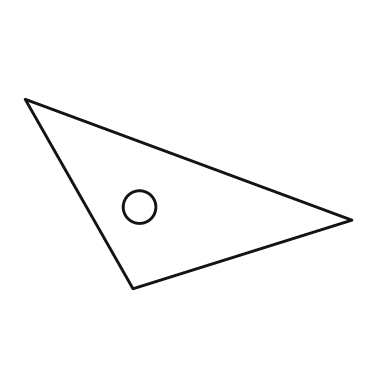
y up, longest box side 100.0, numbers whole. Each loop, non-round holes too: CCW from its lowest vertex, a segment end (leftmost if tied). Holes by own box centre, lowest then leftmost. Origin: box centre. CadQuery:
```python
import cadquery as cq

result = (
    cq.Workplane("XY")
    .moveTo(-17.0, -29.0)
    .lineTo(50.0, -8.0)
    .lineTo(-50.0, 29.0)
    .close()
    .moveTo(-15.0, -4.0)
    .circle(5.0)
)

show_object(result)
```